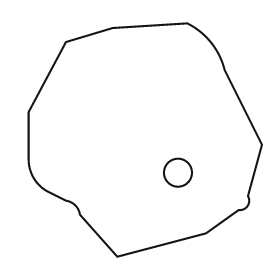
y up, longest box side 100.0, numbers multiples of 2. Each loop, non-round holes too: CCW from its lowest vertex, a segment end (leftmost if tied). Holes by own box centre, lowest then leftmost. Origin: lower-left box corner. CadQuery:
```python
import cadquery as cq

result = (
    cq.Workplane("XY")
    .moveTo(38.0, 0.0)
    .lineTo(76.0, 10.0)
    .lineTo(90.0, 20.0)
    .threePointArc((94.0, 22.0), (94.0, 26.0))
    .lineTo(100.0, 48.0)
    .lineTo(84.0, 80.0)
    .threePointArc((78.0, 92.0), (68.0, 100.0))
    .lineTo(36.0, 98.0)
    .lineTo(16.0, 92.0)
    .lineTo(0.0, 62.0)
    .lineTo(0.0, 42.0)
    .threePointArc((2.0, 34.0), (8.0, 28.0))
    .lineTo(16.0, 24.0)
    .threePointArc((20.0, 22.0), (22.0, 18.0))
    .close()
    .moveTo(64.0, 36.0)
    .circle(6.0)
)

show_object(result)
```